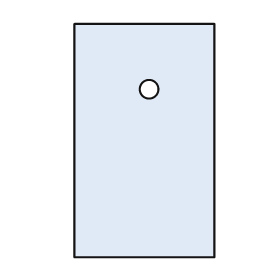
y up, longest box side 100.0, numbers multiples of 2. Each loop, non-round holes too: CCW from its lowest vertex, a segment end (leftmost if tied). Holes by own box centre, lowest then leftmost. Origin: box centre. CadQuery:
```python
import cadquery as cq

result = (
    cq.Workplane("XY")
    .moveTo(-30.0, -50.0)
    .lineTo(30.0, -50.0)
    .lineTo(30.0, 50.0)
    .lineTo(-30.0, 50.0)
    .close()
    .moveTo(2.0, 22.0)
    .circle(4.0)
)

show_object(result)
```